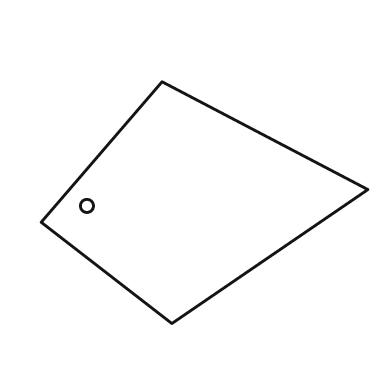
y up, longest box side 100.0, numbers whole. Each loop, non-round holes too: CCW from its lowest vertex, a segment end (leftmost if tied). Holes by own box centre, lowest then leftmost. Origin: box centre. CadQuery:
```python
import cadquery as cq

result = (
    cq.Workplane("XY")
    .moveTo(-10.0, -37.0)
    .lineTo(50.0, 4.0)
    .lineTo(-13.0, 37.0)
    .lineTo(-50.0, -6.0)
    .close()
    .moveTo(-36.0, -1.0)
    .circle(2.0)
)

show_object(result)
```